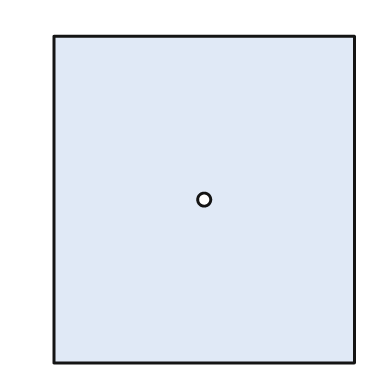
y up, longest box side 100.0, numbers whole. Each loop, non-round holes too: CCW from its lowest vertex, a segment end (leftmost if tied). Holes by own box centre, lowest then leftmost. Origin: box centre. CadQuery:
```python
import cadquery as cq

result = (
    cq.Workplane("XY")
    .moveTo(-46.0, -50.0)
    .lineTo(46.0, -50.0)
    .lineTo(46.0, 50.0)
    .lineTo(-46.0, 50.0)
    .close()
    .moveTo(0.0, 0.0)
    .circle(2.0)
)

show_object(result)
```